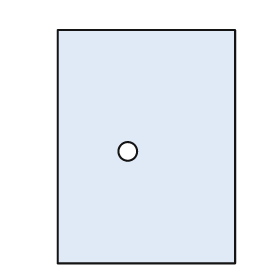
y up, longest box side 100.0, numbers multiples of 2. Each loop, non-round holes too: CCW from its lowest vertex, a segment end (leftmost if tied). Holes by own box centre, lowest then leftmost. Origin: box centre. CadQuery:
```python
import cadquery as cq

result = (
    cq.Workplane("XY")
    .moveTo(-38.0, -50.0)
    .lineTo(38.0, -50.0)
    .lineTo(38.0, 50.0)
    .lineTo(-38.0, 50.0)
    .close()
    .moveTo(-8.0, -2.0)
    .circle(4.0)
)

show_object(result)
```